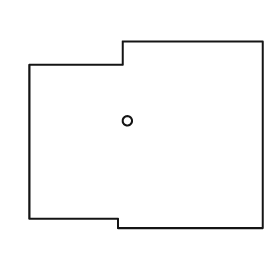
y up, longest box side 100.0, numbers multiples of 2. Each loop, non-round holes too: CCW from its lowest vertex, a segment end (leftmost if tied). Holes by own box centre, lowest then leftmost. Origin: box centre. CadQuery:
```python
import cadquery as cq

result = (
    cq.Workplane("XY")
    .moveTo(-12.0, -40.0)
    .lineTo(50.0, -40.0)
    .lineTo(50.0, 40.0)
    .lineTo(-10.0, 40.0)
    .lineTo(-10.0, 30.0)
    .lineTo(-50.0, 30.0)
    .lineTo(-50.0, -36.0)
    .lineTo(-12.0, -36.0)
    .close()
    .moveTo(-8.0, 6.0)
    .circle(2.0)
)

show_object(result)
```